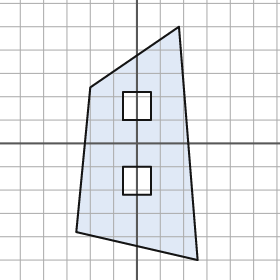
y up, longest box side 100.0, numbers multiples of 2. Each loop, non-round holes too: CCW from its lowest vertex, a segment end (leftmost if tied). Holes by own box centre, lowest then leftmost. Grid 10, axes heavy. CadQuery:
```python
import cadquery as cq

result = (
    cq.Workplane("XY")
    .moveTo(26.0, -50.0)
    .lineTo(18.0, 50.0)
    .lineTo(-20.0, 24.0)
    .lineTo(-26.0, -38.0)
    .close()
    .moveTo(-6.0, -22.0)
    .lineTo(6.0, -22.0)
    .lineTo(6.0, -10.0)
    .lineTo(-6.0, -10.0)
    .close()
    .moveTo(-6.0, 10.0)
    .lineTo(6.0, 10.0)
    .lineTo(6.0, 22.0)
    .lineTo(-6.0, 22.0)
    .close()
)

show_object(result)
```